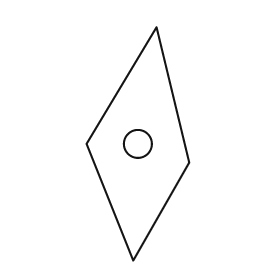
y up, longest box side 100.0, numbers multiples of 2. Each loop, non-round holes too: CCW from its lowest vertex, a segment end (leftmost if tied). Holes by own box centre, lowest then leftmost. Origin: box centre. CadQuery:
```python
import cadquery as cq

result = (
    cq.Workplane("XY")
    .moveTo(-2.0, -50.0)
    .lineTo(22.0, -8.0)
    .lineTo(8.0, 50.0)
    .lineTo(-22.0, 0.0)
    .close()
    .moveTo(0.0, 0.0)
    .circle(6.0)
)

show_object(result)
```